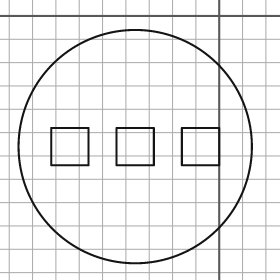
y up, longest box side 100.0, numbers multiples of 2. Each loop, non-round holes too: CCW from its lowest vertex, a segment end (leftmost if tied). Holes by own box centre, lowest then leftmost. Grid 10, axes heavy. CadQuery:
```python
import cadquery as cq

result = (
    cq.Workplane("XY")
    .moveTo(-36.0, -56.0)
    .circle(50.0)
    .moveTo(-72.0, -64.0)
    .lineTo(-56.0, -64.0)
    .lineTo(-56.0, -48.0)
    .lineTo(-72.0, -48.0)
    .close()
    .moveTo(-44.0, -64.0)
    .lineTo(-28.0, -64.0)
    .lineTo(-28.0, -48.0)
    .lineTo(-44.0, -48.0)
    .close()
    .moveTo(-16.0, -64.0)
    .lineTo(0.0, -64.0)
    .lineTo(0.0, -48.0)
    .lineTo(-16.0, -48.0)
    .close()
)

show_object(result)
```